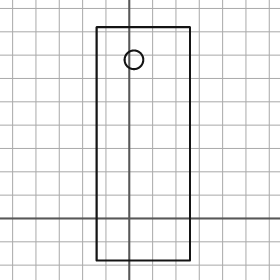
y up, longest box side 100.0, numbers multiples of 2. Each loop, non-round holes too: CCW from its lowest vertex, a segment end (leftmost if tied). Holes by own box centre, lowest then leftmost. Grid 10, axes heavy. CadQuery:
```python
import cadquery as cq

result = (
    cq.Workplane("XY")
    .moveTo(-14.0, -18.0)
    .lineTo(26.0, -18.0)
    .lineTo(26.0, 82.0)
    .lineTo(-14.0, 82.0)
    .close()
    .moveTo(2.0, 68.0)
    .circle(4.0)
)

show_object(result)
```